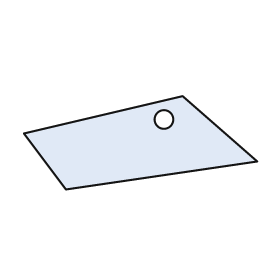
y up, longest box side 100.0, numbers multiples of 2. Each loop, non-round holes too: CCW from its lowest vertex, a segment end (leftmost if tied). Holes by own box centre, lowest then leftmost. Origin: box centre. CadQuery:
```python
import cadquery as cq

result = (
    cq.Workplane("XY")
    .moveTo(-32.0, -20.0)
    .lineTo(50.0, -8.0)
    .lineTo(18.0, 20.0)
    .lineTo(-50.0, 4.0)
    .close()
    .moveTo(10.0, 10.0)
    .circle(4.0)
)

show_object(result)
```